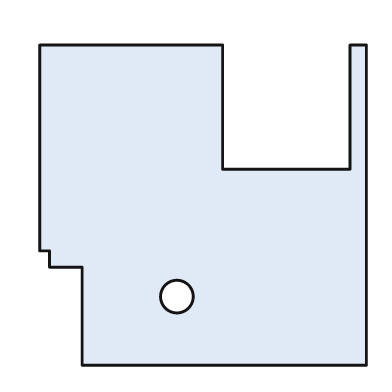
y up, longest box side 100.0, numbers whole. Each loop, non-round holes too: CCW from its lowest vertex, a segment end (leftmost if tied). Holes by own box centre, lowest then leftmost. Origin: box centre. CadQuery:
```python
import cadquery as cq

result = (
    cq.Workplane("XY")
    .moveTo(-37.0, -49.0)
    .lineTo(50.0, -49.0)
    .lineTo(50.0, 49.0)
    .lineTo(45.0, 49.0)
    .lineTo(45.0, 11.0)
    .lineTo(6.0, 11.0)
    .lineTo(6.0, 49.0)
    .lineTo(-50.0, 49.0)
    .lineTo(-50.0, -14.0)
    .lineTo(-47.0, -14.0)
    .lineTo(-47.0, -19.0)
    .lineTo(-37.0, -19.0)
    .close()
    .moveTo(-8.0, -28.0)
    .circle(5.0)
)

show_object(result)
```